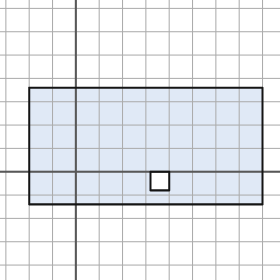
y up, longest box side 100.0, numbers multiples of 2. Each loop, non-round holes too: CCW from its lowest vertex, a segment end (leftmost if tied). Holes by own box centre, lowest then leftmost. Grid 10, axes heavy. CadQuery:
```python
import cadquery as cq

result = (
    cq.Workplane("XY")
    .moveTo(-20.0, -14.0)
    .lineTo(80.0, -14.0)
    .lineTo(80.0, 36.0)
    .lineTo(-20.0, 36.0)
    .close()
    .moveTo(32.0, -8.0)
    .lineTo(40.0, -8.0)
    .lineTo(40.0, 0.0)
    .lineTo(32.0, 0.0)
    .close()
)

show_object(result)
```